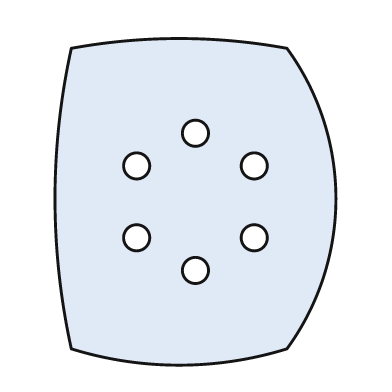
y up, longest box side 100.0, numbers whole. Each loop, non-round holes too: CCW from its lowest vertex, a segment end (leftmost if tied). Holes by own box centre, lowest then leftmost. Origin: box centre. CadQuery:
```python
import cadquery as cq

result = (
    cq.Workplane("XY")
    .moveTo(-38.0, -45.0)
    .threePointArc((-5.0, -50.0), (28.0, -45.0))
    .threePointArc((43.0, 1.0), (28.0, 47.0))
    .threePointArc((-5.0, 50.0), (-38.0, 47.0))
    .threePointArc((-43.0, 1.0), (-38.0, -45.0))
    .close()
    .moveTo(0.0, -21.0)
    .circle(4.0)
    .moveTo(-18.0, -11.0)
    .circle(4.0)
    .moveTo(18.0, -11.0)
    .circle(4.0)
    .moveTo(-18.0, 11.0)
    .circle(4.0)
    .moveTo(18.0, 11.0)
    .circle(4.0)
    .moveTo(0.0, 21.0)
    .circle(4.0)
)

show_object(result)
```